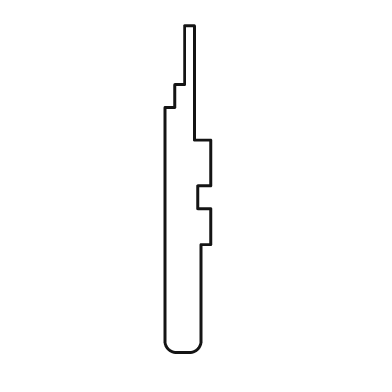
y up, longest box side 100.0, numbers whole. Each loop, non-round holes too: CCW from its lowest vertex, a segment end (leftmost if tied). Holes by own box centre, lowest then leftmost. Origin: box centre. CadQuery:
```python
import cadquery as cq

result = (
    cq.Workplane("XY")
    .moveTo(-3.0, -50.0)
    .lineTo(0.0, -50.0)
    .threePointArc((3.0, -49.0), (4.0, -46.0))
    .lineTo(4.0, -17.0)
    .lineTo(7.0, -17.0)
    .lineTo(7.0, -6.0)
    .lineTo(3.0, -6.0)
    .lineTo(3.0, 1.0)
    .lineTo(7.0, 1.0)
    .lineTo(7.0, 15.0)
    .lineTo(2.0, 15.0)
    .lineTo(2.0, 50.0)
    .lineTo(-1.0, 50.0)
    .lineTo(-1.0, 32.0)
    .lineTo(-4.0, 32.0)
    .lineTo(-4.0, 25.0)
    .lineTo(-7.0, 25.0)
    .lineTo(-7.0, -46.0)
    .threePointArc((-6.0, -49.0), (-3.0, -50.0))
    .close()
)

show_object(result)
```